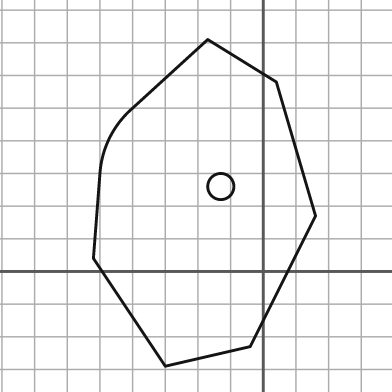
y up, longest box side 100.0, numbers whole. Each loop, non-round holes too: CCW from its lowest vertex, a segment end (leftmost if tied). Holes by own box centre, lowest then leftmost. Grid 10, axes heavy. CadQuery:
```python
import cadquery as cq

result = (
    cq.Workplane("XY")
    .moveTo(-30.0, -29.0)
    .lineTo(-4.0, -23.0)
    .lineTo(16.0, 17.0)
    .lineTo(4.0, 58.0)
    .lineTo(-17.0, 71.0)
    .lineTo(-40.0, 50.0)
    .threePointArc((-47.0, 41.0), (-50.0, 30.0))
    .lineTo(-52.0, 4.0)
    .close()
    .moveTo(-13.0, 26.0)
    .circle(4.0)
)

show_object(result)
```